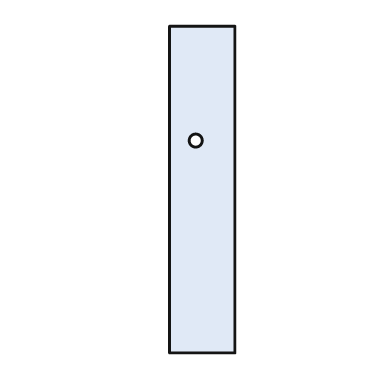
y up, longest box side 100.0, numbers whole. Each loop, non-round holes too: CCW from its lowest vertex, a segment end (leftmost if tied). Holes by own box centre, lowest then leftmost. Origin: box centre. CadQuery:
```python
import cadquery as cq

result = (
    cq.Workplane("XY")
    .moveTo(-10.0, -50.0)
    .lineTo(10.0, -50.0)
    .lineTo(10.0, 50.0)
    .lineTo(-10.0, 50.0)
    .close()
    .moveTo(-2.0, 15.0)
    .circle(2.0)
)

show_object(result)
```